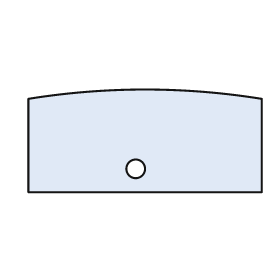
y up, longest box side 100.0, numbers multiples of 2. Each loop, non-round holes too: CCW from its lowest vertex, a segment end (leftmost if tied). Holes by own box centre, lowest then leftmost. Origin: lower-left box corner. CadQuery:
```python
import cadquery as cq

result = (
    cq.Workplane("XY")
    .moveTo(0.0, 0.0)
    .lineTo(100.0, 0.0)
    .lineTo(100.0, 40.0)
    .threePointArc((50.0, 44.0), (0.0, 40.0))
    .close()
    .moveTo(46.0, 10.0)
    .circle(4.0)
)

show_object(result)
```